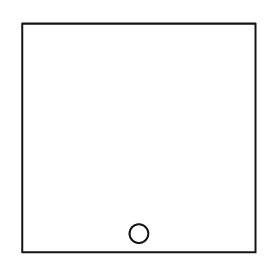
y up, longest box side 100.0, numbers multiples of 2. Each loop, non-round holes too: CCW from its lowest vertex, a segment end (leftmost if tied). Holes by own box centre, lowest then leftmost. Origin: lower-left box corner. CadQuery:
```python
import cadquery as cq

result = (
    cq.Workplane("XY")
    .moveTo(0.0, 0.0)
    .lineTo(100.0, 0.0)
    .lineTo(100.0, 98.0)
    .lineTo(0.0, 98.0)
    .close()
    .moveTo(50.0, 8.0)
    .circle(4.0)
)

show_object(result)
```